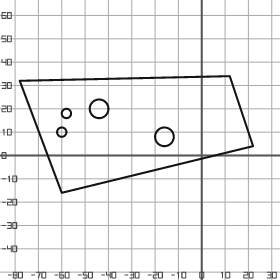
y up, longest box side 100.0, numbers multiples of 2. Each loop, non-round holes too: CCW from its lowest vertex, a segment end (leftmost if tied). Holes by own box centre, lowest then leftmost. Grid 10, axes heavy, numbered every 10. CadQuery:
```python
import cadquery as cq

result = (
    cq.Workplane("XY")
    .moveTo(-60.0, -16.0)
    .lineTo(22.0, 4.0)
    .lineTo(12.0, 34.0)
    .lineTo(-78.0, 32.0)
    .close()
    .moveTo(-16.0, 8.0)
    .circle(4.0)
    .moveTo(-60.0, 10.0)
    .circle(2.0)
    .moveTo(-58.0, 18.0)
    .circle(2.0)
    .moveTo(-44.0, 20.0)
    .circle(4.0)
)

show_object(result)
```